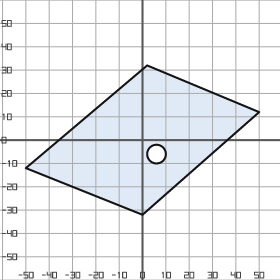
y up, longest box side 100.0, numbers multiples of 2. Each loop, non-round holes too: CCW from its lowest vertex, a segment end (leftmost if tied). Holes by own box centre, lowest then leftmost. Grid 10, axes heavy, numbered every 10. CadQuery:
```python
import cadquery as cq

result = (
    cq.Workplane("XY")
    .moveTo(0.0, -32.0)
    .lineTo(50.0, 12.0)
    .lineTo(2.0, 32.0)
    .lineTo(-50.0, -12.0)
    .close()
    .moveTo(6.0, -6.0)
    .circle(4.0)
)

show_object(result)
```